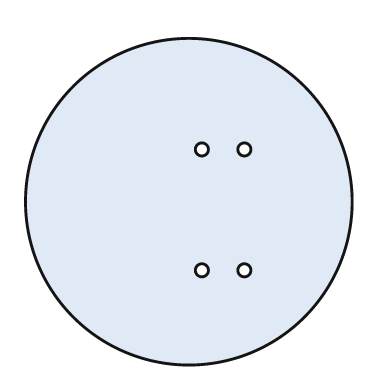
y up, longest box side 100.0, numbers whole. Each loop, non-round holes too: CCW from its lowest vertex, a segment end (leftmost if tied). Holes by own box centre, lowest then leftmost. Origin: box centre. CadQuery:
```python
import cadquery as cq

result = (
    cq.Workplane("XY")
    .moveTo(0.0, 0.0)
    .circle(50.0)
    .moveTo(4.0, -21.0)
    .circle(2.0)
    .moveTo(17.0, -21.0)
    .circle(2.0)
    .moveTo(4.0, 16.0)
    .circle(2.0)
    .moveTo(17.0, 16.0)
    .circle(2.0)
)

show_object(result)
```